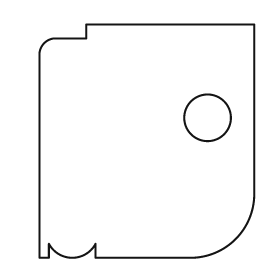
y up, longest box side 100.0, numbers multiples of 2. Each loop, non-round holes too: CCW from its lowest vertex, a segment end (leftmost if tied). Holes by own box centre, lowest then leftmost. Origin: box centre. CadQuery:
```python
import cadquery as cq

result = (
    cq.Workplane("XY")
    .moveTo(-46.0, -50.0)
    .lineTo(-42.0, -50.0)
    .lineTo(-42.0, -44.0)
    .threePointArc((-32.0, -50.0), (-22.0, -44.0))
    .lineTo(-22.0, -50.0)
    .lineTo(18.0, -50.0)
    .threePointArc((38.0, -42.0), (46.0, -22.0))
    .lineTo(46.0, 50.0)
    .lineTo(-26.0, 50.0)
    .lineTo(-26.0, 44.0)
    .lineTo(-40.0, 44.0)
    .threePointArc((-44.0, 42.0), (-46.0, 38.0))
    .close()
    .moveTo(26.0, 10.0)
    .circle(10.0)
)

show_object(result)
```